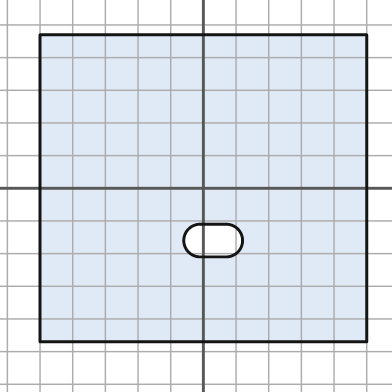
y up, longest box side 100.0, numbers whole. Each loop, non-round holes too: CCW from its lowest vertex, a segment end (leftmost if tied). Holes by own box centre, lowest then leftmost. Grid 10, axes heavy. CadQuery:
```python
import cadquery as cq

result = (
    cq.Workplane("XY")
    .moveTo(-50.0, -47.0)
    .lineTo(50.0, -47.0)
    .lineTo(50.0, 47.0)
    .lineTo(-50.0, 47.0)
    .close()
    .moveTo(-1.0, -21.0)
    .lineTo(7.0, -21.0)
    .threePointArc((12.0, -16.0), (7.0, -11.0))
    .lineTo(-1.0, -11.0)
    .threePointArc((-6.0, -16.0), (-1.0, -21.0))
    .close()
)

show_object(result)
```